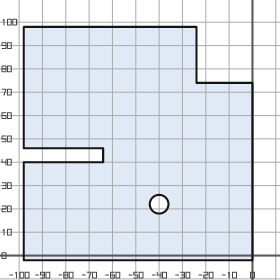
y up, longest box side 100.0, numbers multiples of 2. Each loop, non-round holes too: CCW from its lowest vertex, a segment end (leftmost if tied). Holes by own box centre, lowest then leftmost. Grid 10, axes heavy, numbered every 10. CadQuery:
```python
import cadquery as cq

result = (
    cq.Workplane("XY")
    .moveTo(-98.0, -2.0)
    .lineTo(0.0, -2.0)
    .lineTo(0.0, 74.0)
    .lineTo(-24.0, 74.0)
    .lineTo(-24.0, 98.0)
    .lineTo(-98.0, 98.0)
    .lineTo(-98.0, 46.0)
    .lineTo(-64.0, 46.0)
    .lineTo(-64.0, 40.0)
    .lineTo(-98.0, 40.0)
    .close()
    .moveTo(-40.0, 22.0)
    .circle(4.0)
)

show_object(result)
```